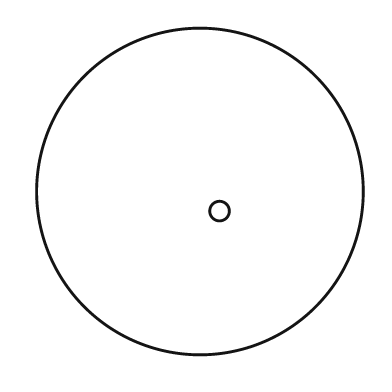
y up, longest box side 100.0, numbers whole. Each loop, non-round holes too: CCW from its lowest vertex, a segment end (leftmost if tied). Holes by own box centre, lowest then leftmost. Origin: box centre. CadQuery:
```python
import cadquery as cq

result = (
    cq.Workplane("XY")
    .moveTo(0.0, 0.0)
    .circle(50.0)
    .moveTo(6.0, -6.0)
    .circle(3.0)
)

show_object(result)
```